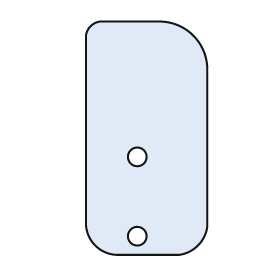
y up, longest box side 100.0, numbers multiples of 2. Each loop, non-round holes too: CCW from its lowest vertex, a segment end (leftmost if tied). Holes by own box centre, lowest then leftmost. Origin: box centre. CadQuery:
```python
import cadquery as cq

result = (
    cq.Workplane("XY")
    .moveTo(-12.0, -50.0)
    .lineTo(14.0, -50.0)
    .threePointArc((22.0, -46.0), (26.0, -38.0))
    .lineTo(26.0, 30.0)
    .threePointArc((20.0, 44.0), (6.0, 50.0))
    .lineTo(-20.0, 50.0)
    .threePointArc((-24.0, 48.0), (-26.0, 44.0))
    .lineTo(-26.0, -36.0)
    .threePointArc((-22.0, -46.0), (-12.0, -50.0))
    .close()
    .moveTo(-4.0, -42.0)
    .circle(4.0)
    .moveTo(-4.0, -8.0)
    .circle(4.0)
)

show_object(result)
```